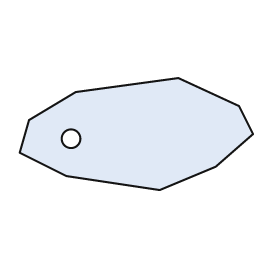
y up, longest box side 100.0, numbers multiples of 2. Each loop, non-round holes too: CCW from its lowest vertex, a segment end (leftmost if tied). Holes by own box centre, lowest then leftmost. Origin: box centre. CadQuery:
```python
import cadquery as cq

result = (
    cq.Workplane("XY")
    .moveTo(10.0, -24.0)
    .lineTo(34.0, -14.0)
    .lineTo(50.0, 0.0)
    .lineTo(44.0, 12.0)
    .lineTo(18.0, 24.0)
    .lineTo(-26.0, 18.0)
    .lineTo(-46.0, 6.0)
    .lineTo(-50.0, -8.0)
    .lineTo(-30.0, -18.0)
    .close()
    .moveTo(-28.0, -2.0)
    .circle(4.0)
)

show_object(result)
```